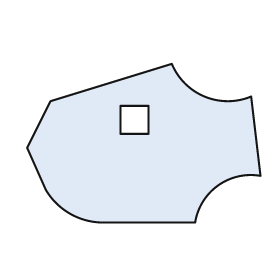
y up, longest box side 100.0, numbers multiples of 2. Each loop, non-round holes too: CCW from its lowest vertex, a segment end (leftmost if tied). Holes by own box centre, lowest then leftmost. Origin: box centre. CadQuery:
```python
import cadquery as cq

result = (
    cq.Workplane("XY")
    .moveTo(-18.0, -34.0)
    .lineTo(22.0, -34.0)
    .threePointArc((32.0, -18.0), (50.0, -14.0))
    .lineTo(46.0, 20.0)
    .threePointArc((26.0, 20.0), (12.0, 34.0))
    .lineTo(-40.0, 18.0)
    .lineTo(-50.0, -2.0)
    .lineTo(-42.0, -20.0)
    .threePointArc((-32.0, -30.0), (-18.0, -34.0))
    .close()
    .moveTo(-10.0, 4.0)
    .lineTo(2.0, 4.0)
    .lineTo(2.0, 16.0)
    .lineTo(-10.0, 16.0)
    .close()
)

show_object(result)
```